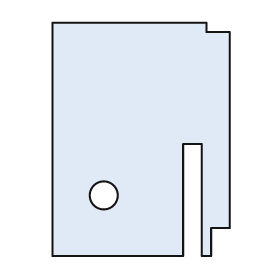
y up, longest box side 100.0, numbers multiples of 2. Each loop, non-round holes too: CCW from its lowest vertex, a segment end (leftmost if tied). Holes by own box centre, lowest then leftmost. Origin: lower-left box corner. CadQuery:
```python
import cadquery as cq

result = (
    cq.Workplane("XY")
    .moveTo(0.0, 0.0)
    .lineTo(56.0, 0.0)
    .lineTo(56.0, 48.0)
    .lineTo(64.0, 48.0)
    .lineTo(64.0, 0.0)
    .lineTo(68.0, 0.0)
    .lineTo(68.0, 12.0)
    .lineTo(76.0, 12.0)
    .lineTo(76.0, 96.0)
    .lineTo(66.0, 96.0)
    .lineTo(66.0, 100.0)
    .lineTo(0.0, 100.0)
    .close()
    .moveTo(22.0, 26.0)
    .circle(6.0)
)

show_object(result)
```